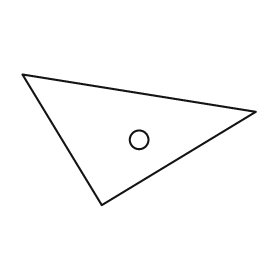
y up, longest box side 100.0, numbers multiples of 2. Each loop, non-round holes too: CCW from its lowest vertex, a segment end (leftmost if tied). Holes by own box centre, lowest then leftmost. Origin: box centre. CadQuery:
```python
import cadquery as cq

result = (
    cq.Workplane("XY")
    .moveTo(-16.0, -28.0)
    .lineTo(50.0, 12.0)
    .lineTo(-50.0, 28.0)
    .close()
    .moveTo(0.0, 0.0)
    .circle(4.0)
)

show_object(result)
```